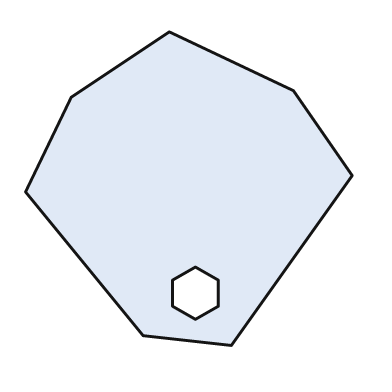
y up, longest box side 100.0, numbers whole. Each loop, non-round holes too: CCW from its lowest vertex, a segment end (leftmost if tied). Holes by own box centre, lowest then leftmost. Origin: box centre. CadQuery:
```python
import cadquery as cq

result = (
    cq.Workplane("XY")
    .moveTo(13.0, -48.0)
    .lineTo(50.0, 4.0)
    .lineTo(32.0, 30.0)
    .lineTo(-6.0, 48.0)
    .lineTo(-36.0, 28.0)
    .lineTo(-50.0, -1.0)
    .lineTo(-14.0, -45.0)
    .close()
    .moveTo(2.0, -40.0)
    .lineTo(9.0, -36.0)
    .lineTo(9.0, -28.0)
    .lineTo(2.0, -24.0)
    .lineTo(-5.0, -28.0)
    .lineTo(-5.0, -36.0)
    .close()
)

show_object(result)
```